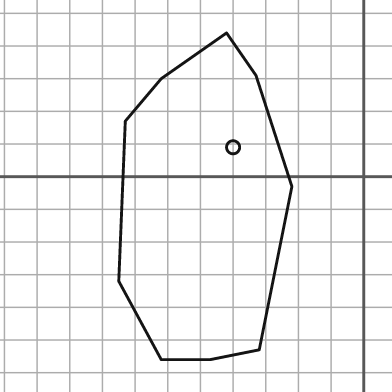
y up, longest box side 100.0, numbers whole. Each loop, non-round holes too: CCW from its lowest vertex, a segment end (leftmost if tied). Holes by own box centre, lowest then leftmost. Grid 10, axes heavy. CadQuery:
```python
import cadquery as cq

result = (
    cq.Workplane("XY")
    .moveTo(-62.0, -56.0)
    .lineTo(-47.0, -56.0)
    .lineTo(-32.0, -53.0)
    .lineTo(-22.0, -3.0)
    .lineTo(-33.0, 31.0)
    .lineTo(-42.0, 44.0)
    .lineTo(-62.0, 30.0)
    .lineTo(-73.0, 17.0)
    .lineTo(-75.0, -32.0)
    .close()
    .moveTo(-40.0, 9.0)
    .circle(2.0)
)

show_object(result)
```